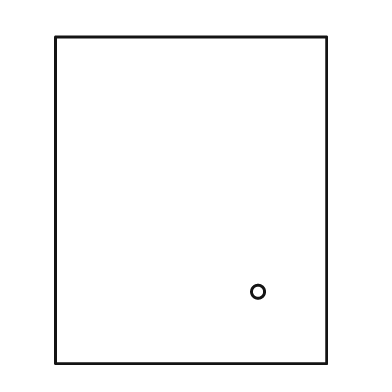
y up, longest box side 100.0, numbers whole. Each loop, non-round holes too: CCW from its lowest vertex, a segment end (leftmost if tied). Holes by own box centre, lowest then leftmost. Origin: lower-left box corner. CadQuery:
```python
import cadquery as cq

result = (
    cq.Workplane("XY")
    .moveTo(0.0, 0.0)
    .lineTo(83.0, 0.0)
    .lineTo(83.0, 100.0)
    .lineTo(0.0, 100.0)
    .close()
    .moveTo(62.0, 22.0)
    .circle(2.0)
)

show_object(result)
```